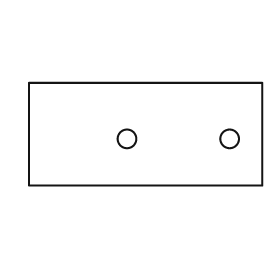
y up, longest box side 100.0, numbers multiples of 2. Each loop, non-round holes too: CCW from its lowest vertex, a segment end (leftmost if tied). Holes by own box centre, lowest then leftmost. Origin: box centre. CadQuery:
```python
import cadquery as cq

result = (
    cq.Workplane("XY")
    .moveTo(-50.0, -22.0)
    .lineTo(50.0, -22.0)
    .lineTo(50.0, 22.0)
    .lineTo(-50.0, 22.0)
    .close()
    .moveTo(-8.0, -2.0)
    .circle(4.0)
    .moveTo(36.0, -2.0)
    .circle(4.0)
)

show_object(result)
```